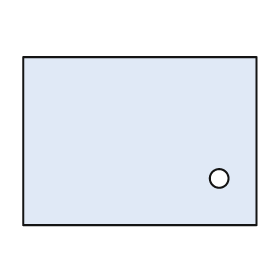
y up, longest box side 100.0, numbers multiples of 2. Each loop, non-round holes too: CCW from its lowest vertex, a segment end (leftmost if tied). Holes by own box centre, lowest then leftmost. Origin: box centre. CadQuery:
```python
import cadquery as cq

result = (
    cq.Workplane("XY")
    .moveTo(-50.0, -36.0)
    .lineTo(50.0, -36.0)
    .lineTo(50.0, 36.0)
    .lineTo(-50.0, 36.0)
    .close()
    .moveTo(34.0, -16.0)
    .circle(4.0)
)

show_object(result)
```